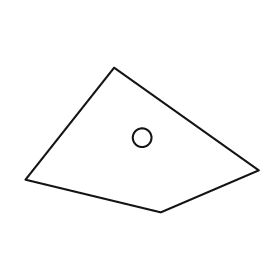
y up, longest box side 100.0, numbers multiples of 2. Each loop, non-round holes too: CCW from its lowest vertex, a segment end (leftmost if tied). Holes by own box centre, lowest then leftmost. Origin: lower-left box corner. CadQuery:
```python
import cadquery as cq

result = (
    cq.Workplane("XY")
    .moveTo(58.0, 0.0)
    .lineTo(100.0, 18.0)
    .lineTo(38.0, 62.0)
    .lineTo(0.0, 14.0)
    .close()
    .moveTo(50.0, 32.0)
    .circle(4.0)
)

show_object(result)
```